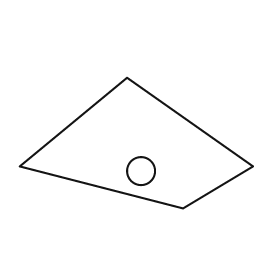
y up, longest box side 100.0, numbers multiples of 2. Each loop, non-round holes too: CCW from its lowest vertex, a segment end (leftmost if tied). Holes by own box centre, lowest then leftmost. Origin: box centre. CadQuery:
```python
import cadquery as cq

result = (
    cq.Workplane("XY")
    .moveTo(20.0, -28.0)
    .lineTo(50.0, -10.0)
    .lineTo(-4.0, 28.0)
    .lineTo(-50.0, -10.0)
    .close()
    .moveTo(2.0, -12.0)
    .circle(6.0)
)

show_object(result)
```